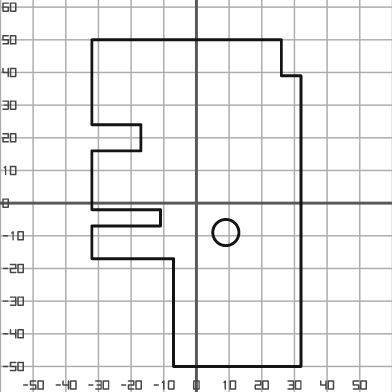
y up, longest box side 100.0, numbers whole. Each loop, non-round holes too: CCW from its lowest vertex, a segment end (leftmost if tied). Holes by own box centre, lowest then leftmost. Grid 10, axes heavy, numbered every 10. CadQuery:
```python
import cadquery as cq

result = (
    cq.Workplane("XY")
    .moveTo(-7.0, -50.0)
    .lineTo(32.0, -50.0)
    .lineTo(32.0, 39.0)
    .lineTo(26.0, 39.0)
    .lineTo(26.0, 50.0)
    .lineTo(-32.0, 50.0)
    .lineTo(-32.0, 24.0)
    .lineTo(-17.0, 24.0)
    .lineTo(-17.0, 16.0)
    .lineTo(-32.0, 16.0)
    .lineTo(-32.0, -2.0)
    .lineTo(-11.0, -2.0)
    .lineTo(-11.0, -7.0)
    .lineTo(-32.0, -7.0)
    .lineTo(-32.0, -17.0)
    .lineTo(-7.0, -17.0)
    .close()
    .moveTo(9.0, -9.0)
    .circle(4.0)
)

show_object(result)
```